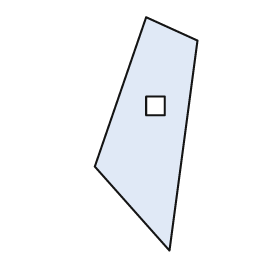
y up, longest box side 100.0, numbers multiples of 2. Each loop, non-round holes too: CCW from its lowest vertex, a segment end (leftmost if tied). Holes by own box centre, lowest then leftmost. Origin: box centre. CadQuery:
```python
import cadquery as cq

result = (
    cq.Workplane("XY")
    .moveTo(10.0, -50.0)
    .lineTo(22.0, 40.0)
    .lineTo(0.0, 50.0)
    .lineTo(-22.0, -14.0)
    .close()
    .moveTo(0.0, 8.0)
    .lineTo(8.0, 8.0)
    .lineTo(8.0, 16.0)
    .lineTo(0.0, 16.0)
    .close()
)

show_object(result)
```